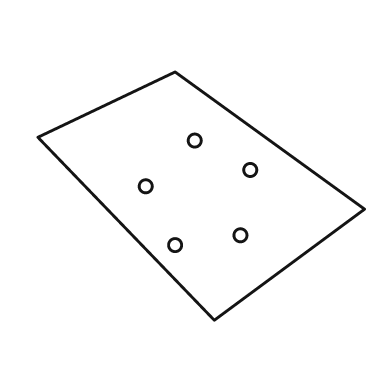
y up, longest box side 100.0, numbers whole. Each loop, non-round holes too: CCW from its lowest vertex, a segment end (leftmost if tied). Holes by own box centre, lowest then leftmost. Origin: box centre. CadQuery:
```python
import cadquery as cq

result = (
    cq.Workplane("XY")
    .moveTo(4.0, -38.0)
    .lineTo(50.0, -4.0)
    .lineTo(-8.0, 38.0)
    .lineTo(-50.0, 18.0)
    .close()
    .moveTo(-8.0, -15.0)
    .circle(2.0)
    .moveTo(12.0, -12.0)
    .circle(2.0)
    .moveTo(-17.0, 3.0)
    .circle(2.0)
    .moveTo(15.0, 8.0)
    .circle(2.0)
    .moveTo(-2.0, 17.0)
    .circle(2.0)
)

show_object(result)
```